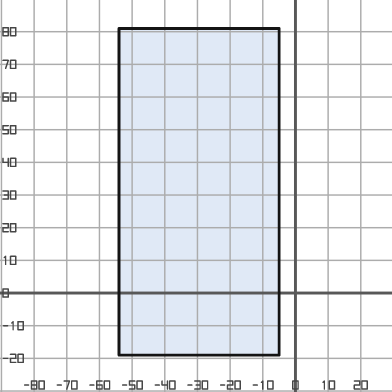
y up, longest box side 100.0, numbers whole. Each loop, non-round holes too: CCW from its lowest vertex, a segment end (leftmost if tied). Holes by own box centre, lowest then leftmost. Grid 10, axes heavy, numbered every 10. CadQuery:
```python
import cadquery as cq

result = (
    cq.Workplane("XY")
    .moveTo(-54.0, -19.0)
    .lineTo(-5.0, -19.0)
    .lineTo(-5.0, 81.0)
    .lineTo(-54.0, 81.0)
    .close()
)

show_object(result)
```